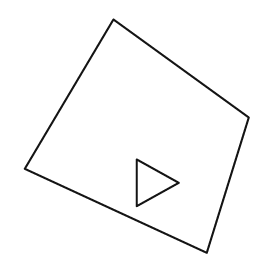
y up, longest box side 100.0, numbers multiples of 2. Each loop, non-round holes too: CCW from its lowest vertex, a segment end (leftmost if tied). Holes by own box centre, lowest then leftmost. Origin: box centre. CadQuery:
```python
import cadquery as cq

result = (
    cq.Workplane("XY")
    .moveTo(30.0, -50.0)
    .lineTo(48.0, 8.0)
    .lineTo(-10.0, 50.0)
    .lineTo(-48.0, -14.0)
    .close()
    .moveTo(0.0, -30.0)
    .lineTo(18.0, -20.0)
    .lineTo(0.0, -10.0)
    .close()
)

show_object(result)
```